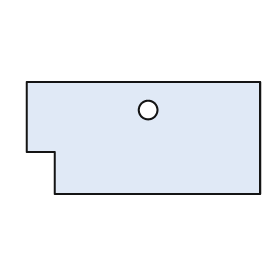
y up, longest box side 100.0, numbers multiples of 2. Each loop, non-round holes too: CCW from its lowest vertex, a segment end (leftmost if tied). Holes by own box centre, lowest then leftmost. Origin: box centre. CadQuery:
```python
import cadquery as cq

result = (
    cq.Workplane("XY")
    .moveTo(-38.0, -24.0)
    .lineTo(50.0, -24.0)
    .lineTo(50.0, 24.0)
    .lineTo(-50.0, 24.0)
    .lineTo(-50.0, -6.0)
    .lineTo(-38.0, -6.0)
    .close()
    .moveTo(2.0, 12.0)
    .circle(4.0)
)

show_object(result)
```